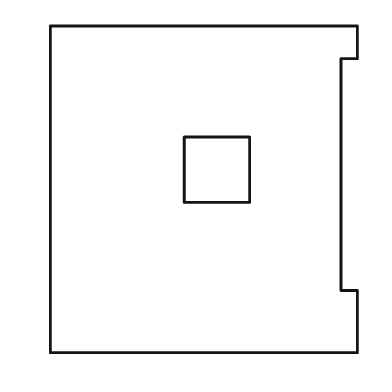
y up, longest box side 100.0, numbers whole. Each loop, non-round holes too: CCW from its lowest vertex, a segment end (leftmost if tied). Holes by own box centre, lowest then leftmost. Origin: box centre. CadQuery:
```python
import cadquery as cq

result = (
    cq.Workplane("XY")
    .moveTo(-47.0, -50.0)
    .lineTo(47.0, -50.0)
    .lineTo(47.0, -31.0)
    .lineTo(42.0, -31.0)
    .lineTo(42.0, 40.0)
    .lineTo(47.0, 40.0)
    .lineTo(47.0, 50.0)
    .lineTo(-47.0, 50.0)
    .close()
    .moveTo(-6.0, -4.0)
    .lineTo(14.0, -4.0)
    .lineTo(14.0, 16.0)
    .lineTo(-6.0, 16.0)
    .close()
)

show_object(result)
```